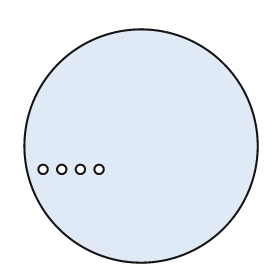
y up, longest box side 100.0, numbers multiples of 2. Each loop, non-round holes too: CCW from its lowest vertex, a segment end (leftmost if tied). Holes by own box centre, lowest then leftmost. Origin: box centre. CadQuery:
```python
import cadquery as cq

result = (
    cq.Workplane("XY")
    .moveTo(0.0, 0.0)
    .circle(50.0)
    .moveTo(-42.0, -10.0)
    .circle(2.0)
    .moveTo(-34.0, -10.0)
    .circle(2.0)
    .moveTo(-26.0, -10.0)
    .circle(2.0)
    .moveTo(-18.0, -10.0)
    .circle(2.0)
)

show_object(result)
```